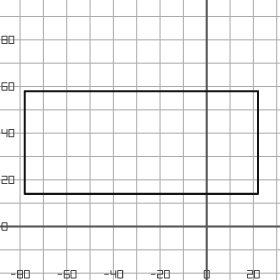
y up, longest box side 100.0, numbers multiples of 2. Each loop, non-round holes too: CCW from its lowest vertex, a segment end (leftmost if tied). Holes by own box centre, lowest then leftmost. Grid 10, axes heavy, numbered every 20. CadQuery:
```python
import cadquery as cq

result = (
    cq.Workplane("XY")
    .moveTo(-78.0, 14.0)
    .lineTo(22.0, 14.0)
    .lineTo(22.0, 58.0)
    .lineTo(-78.0, 58.0)
    .close()
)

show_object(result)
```